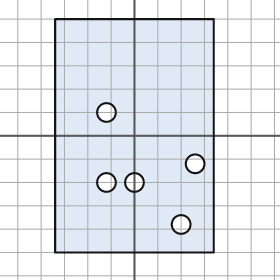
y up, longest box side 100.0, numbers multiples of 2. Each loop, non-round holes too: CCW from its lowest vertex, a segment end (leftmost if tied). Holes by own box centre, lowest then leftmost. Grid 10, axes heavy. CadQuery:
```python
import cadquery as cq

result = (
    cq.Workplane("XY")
    .moveTo(-34.0, -50.0)
    .lineTo(34.0, -50.0)
    .lineTo(34.0, 50.0)
    .lineTo(-34.0, 50.0)
    .close()
    .moveTo(20.0, -38.0)
    .circle(4.0)
    .moveTo(-12.0, -20.0)
    .circle(4.0)
    .moveTo(0.0, -20.0)
    .circle(4.0)
    .moveTo(26.0, -12.0)
    .circle(4.0)
    .moveTo(-12.0, 10.0)
    .circle(4.0)
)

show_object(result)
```